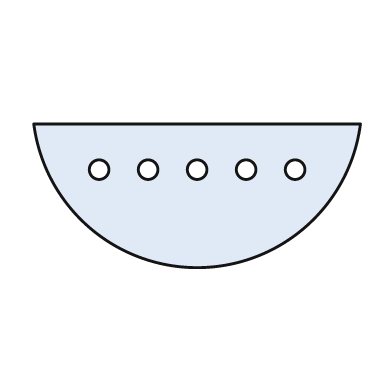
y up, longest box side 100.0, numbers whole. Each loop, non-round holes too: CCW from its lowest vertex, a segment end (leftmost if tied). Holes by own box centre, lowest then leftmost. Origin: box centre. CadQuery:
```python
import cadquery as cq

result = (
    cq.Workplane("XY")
    .moveTo(-50.0, 22.0)
    .threePointArc((0.0, -22.0), (50.0, 22.0))
    .close()
    .moveTo(-30.0, 8.0)
    .circle(3.0)
    .moveTo(-15.0, 8.0)
    .circle(3.0)
    .moveTo(0.0, 8.0)
    .circle(3.0)
    .moveTo(15.0, 8.0)
    .circle(3.0)
    .moveTo(30.0, 8.0)
    .circle(3.0)
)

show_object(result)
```